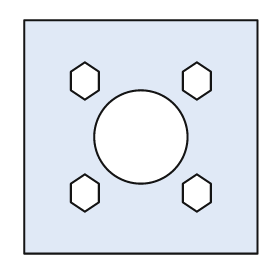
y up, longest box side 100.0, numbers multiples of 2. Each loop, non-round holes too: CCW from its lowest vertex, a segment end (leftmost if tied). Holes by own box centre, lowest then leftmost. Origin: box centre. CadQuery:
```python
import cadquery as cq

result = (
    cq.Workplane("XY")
    .moveTo(-50.0, -50.0)
    .lineTo(50.0, -50.0)
    .lineTo(50.0, 50.0)
    .lineTo(-50.0, 50.0)
    .close()
    .moveTo(-24.0, -32.0)
    .lineTo(-18.0, -28.0)
    .lineTo(-18.0, -20.0)
    .lineTo(-24.0, -16.0)
    .lineTo(-30.0, -20.0)
    .lineTo(-30.0, -28.0)
    .close()
    .moveTo(24.0, -32.0)
    .lineTo(30.0, -28.0)
    .lineTo(30.0, -20.0)
    .lineTo(24.0, -16.0)
    .lineTo(18.0, -20.0)
    .lineTo(18.0, -28.0)
    .close()
    .moveTo(0.0, 0.0)
    .circle(20.0)
    .moveTo(-24.0, 16.0)
    .lineTo(-18.0, 20.0)
    .lineTo(-18.0, 28.0)
    .lineTo(-24.0, 32.0)
    .lineTo(-30.0, 28.0)
    .lineTo(-30.0, 20.0)
    .close()
    .moveTo(24.0, 16.0)
    .lineTo(30.0, 20.0)
    .lineTo(30.0, 28.0)
    .lineTo(24.0, 32.0)
    .lineTo(18.0, 28.0)
    .lineTo(18.0, 20.0)
    .close()
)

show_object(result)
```